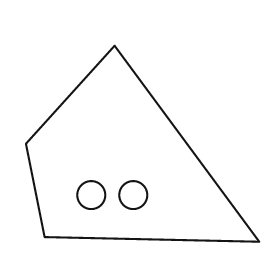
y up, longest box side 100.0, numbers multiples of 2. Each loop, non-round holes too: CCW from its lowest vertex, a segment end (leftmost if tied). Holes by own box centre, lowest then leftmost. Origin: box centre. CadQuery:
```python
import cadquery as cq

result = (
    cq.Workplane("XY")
    .moveTo(50.0, -42.0)
    .lineTo(-12.0, 42.0)
    .lineTo(-50.0, 0.0)
    .lineTo(-42.0, -40.0)
    .close()
    .moveTo(-22.0, -22.0)
    .circle(6.0)
    .moveTo(-4.0, -22.0)
    .circle(6.0)
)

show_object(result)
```